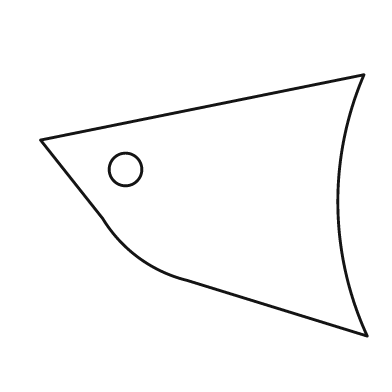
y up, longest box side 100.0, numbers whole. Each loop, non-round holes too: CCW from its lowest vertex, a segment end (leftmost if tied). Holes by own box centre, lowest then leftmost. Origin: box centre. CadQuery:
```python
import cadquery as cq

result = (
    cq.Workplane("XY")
    .moveTo(50.0, -40.0)
    .threePointArc((41.0, 0.0), (49.0, 40.0))
    .lineTo(-50.0, 20.0)
    .lineTo(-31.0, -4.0)
    .threePointArc((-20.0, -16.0), (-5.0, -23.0))
    .close()
    .moveTo(-24.0, 11.0)
    .circle(5.0)
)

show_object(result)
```